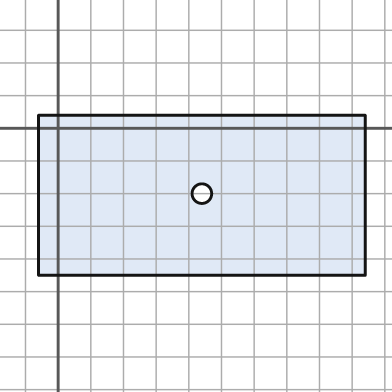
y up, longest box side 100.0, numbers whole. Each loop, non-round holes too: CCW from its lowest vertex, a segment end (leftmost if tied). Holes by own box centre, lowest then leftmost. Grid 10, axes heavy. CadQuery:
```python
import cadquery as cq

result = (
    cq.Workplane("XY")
    .moveTo(-6.0, -45.0)
    .lineTo(94.0, -45.0)
    .lineTo(94.0, 4.0)
    .lineTo(-6.0, 4.0)
    .close()
    .moveTo(44.0, -20.0)
    .circle(3.0)
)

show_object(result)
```